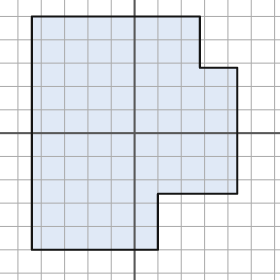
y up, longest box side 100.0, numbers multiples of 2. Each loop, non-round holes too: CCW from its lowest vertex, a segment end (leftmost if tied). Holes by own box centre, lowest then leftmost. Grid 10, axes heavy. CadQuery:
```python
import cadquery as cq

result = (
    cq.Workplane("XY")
    .moveTo(-44.0, -50.0)
    .lineTo(10.0, -50.0)
    .lineTo(10.0, -26.0)
    .lineTo(44.0, -26.0)
    .lineTo(44.0, 28.0)
    .lineTo(28.0, 28.0)
    .lineTo(28.0, 50.0)
    .lineTo(-44.0, 50.0)
    .close()
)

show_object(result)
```